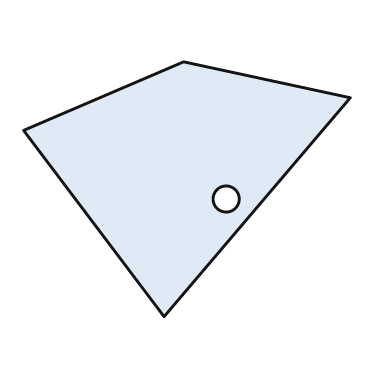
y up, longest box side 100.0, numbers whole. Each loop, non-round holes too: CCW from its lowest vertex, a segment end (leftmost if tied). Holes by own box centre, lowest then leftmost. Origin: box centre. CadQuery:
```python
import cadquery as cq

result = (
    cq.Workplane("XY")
    .moveTo(-7.0, -39.0)
    .lineTo(50.0, 28.0)
    .lineTo(-1.0, 39.0)
    .lineTo(-50.0, 18.0)
    .close()
    .moveTo(12.0, -3.0)
    .circle(4.0)
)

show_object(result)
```